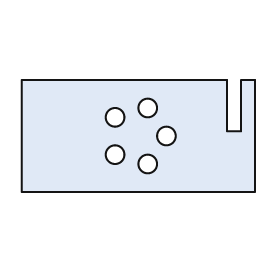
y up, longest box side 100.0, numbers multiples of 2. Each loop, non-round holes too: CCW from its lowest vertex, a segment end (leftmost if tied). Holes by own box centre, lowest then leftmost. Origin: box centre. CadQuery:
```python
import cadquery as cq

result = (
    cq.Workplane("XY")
    .moveTo(-50.0, -24.0)
    .lineTo(50.0, -24.0)
    .lineTo(50.0, 24.0)
    .lineTo(44.0, 24.0)
    .lineTo(44.0, 2.0)
    .lineTo(38.0, 2.0)
    .lineTo(38.0, 24.0)
    .lineTo(-50.0, 24.0)
    .close()
    .moveTo(4.0, -12.0)
    .circle(4.0)
    .moveTo(-10.0, -8.0)
    .circle(4.0)
    .moveTo(12.0, 0.0)
    .circle(4.0)
    .moveTo(-10.0, 8.0)
    .circle(4.0)
    .moveTo(4.0, 12.0)
    .circle(4.0)
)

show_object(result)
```